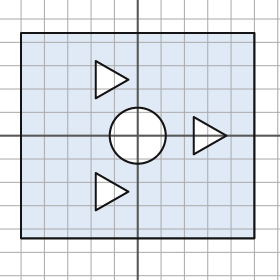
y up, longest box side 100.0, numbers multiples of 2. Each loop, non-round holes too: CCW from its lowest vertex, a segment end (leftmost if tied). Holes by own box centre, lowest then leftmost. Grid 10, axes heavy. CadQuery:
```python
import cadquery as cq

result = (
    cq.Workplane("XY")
    .moveTo(-50.0, -44.0)
    .lineTo(50.0, -44.0)
    .lineTo(50.0, 44.0)
    .lineTo(-50.0, 44.0)
    .close()
    .moveTo(-18.0, -32.0)
    .lineTo(-4.0, -24.0)
    .lineTo(-18.0, -16.0)
    .close()
    .moveTo(0.0, 0.0)
    .circle(12.0)
    .moveTo(24.0, -8.0)
    .lineTo(38.0, 0.0)
    .lineTo(24.0, 8.0)
    .close()
    .moveTo(-18.0, 16.0)
    .lineTo(-4.0, 24.0)
    .lineTo(-18.0, 32.0)
    .close()
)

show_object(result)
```